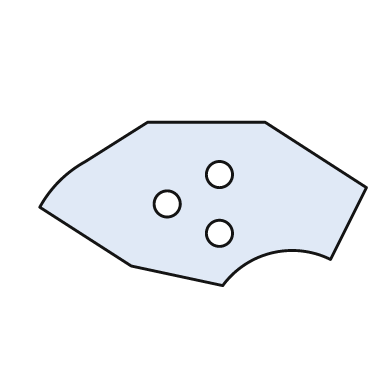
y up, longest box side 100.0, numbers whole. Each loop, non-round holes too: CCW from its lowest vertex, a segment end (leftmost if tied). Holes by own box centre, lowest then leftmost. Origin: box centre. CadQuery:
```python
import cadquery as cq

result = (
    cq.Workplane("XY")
    .moveTo(6.0, -25.0)
    .threePointArc((21.0, -15.0), (39.0, -17.0))
    .lineTo(50.0, 5.0)
    .lineTo(19.0, 25.0)
    .lineTo(-17.0, 25.0)
    .lineTo(-36.0, 13.0)
    .threePointArc((-44.0, 7.0), (-50.0, -1.0))
    .lineTo(-22.0, -19.0)
    .close()
    .moveTo(5.0, -9.0)
    .circle(4.0)
    .moveTo(-11.0, 0.0)
    .circle(4.0)
    .moveTo(5.0, 9.0)
    .circle(4.0)
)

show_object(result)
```